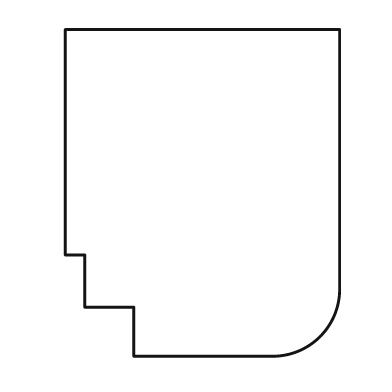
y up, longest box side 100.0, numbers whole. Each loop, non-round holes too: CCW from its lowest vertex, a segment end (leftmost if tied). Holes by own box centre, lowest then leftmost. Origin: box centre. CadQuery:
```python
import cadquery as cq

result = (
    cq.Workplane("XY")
    .moveTo(-21.0, -50.0)
    .lineTo(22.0, -50.0)
    .threePointArc((36.0, -44.0), (42.0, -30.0))
    .lineTo(42.0, 50.0)
    .lineTo(-42.0, 50.0)
    .lineTo(-42.0, -19.0)
    .lineTo(-36.0, -19.0)
    .lineTo(-36.0, -35.0)
    .lineTo(-21.0, -35.0)
    .close()
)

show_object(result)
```